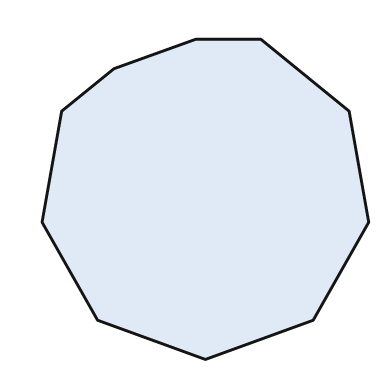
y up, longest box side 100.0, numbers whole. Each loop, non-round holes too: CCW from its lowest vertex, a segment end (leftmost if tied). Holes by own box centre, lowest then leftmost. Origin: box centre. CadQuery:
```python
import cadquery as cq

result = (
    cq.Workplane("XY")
    .moveTo(0.0, -49.0)
    .lineTo(33.0, -37.0)
    .lineTo(50.0, -7.0)
    .lineTo(44.0, 27.0)
    .lineTo(17.0, 49.0)
    .lineTo(-3.0, 49.0)
    .lineTo(-28.0, 40.0)
    .lineTo(-44.0, 27.0)
    .lineTo(-50.0, -7.0)
    .lineTo(-33.0, -37.0)
    .close()
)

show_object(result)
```